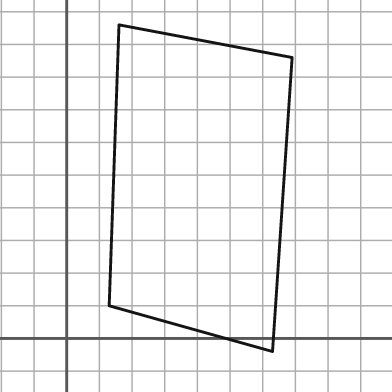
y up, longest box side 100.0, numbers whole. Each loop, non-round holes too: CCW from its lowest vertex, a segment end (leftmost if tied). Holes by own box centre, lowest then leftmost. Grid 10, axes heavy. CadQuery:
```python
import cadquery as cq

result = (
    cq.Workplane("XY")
    .moveTo(63.0, -4.0)
    .lineTo(69.0, 86.0)
    .lineTo(16.0, 96.0)
    .lineTo(13.0, 10.0)
    .close()
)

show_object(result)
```